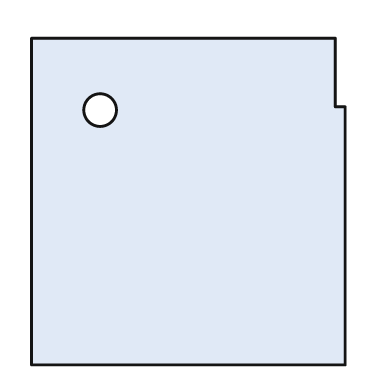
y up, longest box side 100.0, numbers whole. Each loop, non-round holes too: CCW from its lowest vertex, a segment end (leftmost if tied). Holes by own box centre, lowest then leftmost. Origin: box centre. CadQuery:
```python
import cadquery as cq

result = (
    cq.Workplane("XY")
    .moveTo(-48.0, -50.0)
    .lineTo(48.0, -50.0)
    .lineTo(48.0, 29.0)
    .lineTo(45.0, 29.0)
    .lineTo(45.0, 50.0)
    .lineTo(-48.0, 50.0)
    .close()
    .moveTo(-27.0, 28.0)
    .circle(5.0)
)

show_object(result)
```